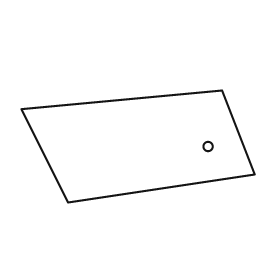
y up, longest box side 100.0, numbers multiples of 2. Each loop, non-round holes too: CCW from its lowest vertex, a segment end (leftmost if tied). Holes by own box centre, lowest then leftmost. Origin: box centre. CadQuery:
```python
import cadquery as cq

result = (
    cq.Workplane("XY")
    .moveTo(-30.0, -24.0)
    .lineTo(50.0, -12.0)
    .lineTo(36.0, 24.0)
    .lineTo(-50.0, 16.0)
    .close()
    .moveTo(30.0, 0.0)
    .circle(2.0)
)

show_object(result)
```